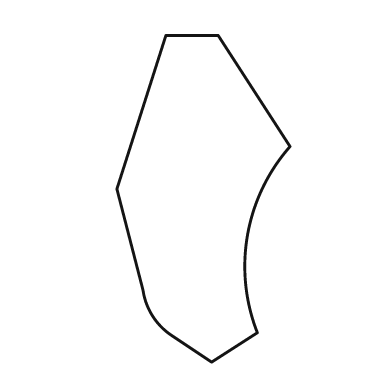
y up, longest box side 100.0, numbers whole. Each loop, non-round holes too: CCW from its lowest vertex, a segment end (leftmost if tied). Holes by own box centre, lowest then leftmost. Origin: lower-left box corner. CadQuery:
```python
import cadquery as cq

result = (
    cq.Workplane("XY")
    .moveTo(29.0, 0.0)
    .lineTo(43.0, 9.0)
    .threePointArc((40.0, 39.0), (53.0, 66.0))
    .lineTo(31.0, 100.0)
    .lineTo(15.0, 100.0)
    .lineTo(0.0, 53.0)
    .lineTo(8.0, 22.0)
    .threePointArc((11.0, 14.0), (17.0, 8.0))
    .close()
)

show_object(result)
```